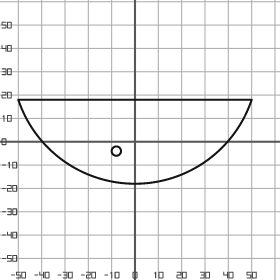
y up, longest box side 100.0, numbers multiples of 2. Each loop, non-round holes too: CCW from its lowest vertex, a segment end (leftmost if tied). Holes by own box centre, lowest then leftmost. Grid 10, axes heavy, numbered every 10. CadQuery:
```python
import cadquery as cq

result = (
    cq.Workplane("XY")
    .moveTo(-50.0, 18.0)
    .threePointArc((0.0, -18.0), (50.0, 18.0))
    .close()
    .moveTo(-8.0, -4.0)
    .circle(2.0)
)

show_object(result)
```